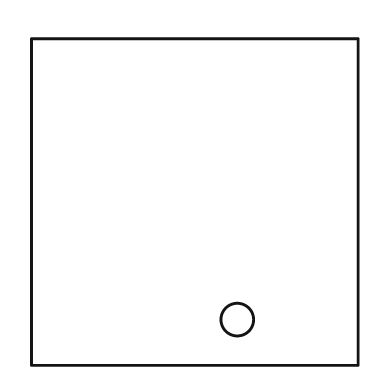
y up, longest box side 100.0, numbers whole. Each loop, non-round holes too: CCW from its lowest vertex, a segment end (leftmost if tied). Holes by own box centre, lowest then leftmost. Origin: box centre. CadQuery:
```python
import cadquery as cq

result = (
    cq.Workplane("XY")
    .moveTo(-50.0, -50.0)
    .lineTo(50.0, -50.0)
    .lineTo(50.0, 50.0)
    .lineTo(-50.0, 50.0)
    .close()
    .moveTo(13.0, -36.0)
    .circle(5.0)
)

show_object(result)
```